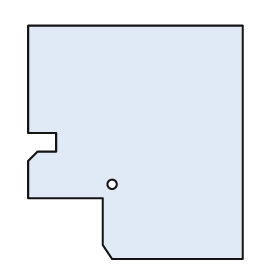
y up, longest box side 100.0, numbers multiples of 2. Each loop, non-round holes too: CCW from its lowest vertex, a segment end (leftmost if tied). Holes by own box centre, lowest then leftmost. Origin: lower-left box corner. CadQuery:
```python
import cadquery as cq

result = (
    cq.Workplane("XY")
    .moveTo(36.0, 0.0)
    .lineTo(92.0, 0.0)
    .lineTo(92.0, 100.0)
    .lineTo(0.0, 100.0)
    .lineTo(0.0, 54.0)
    .lineTo(12.0, 54.0)
    .lineTo(12.0, 46.0)
    .lineTo(4.0, 46.0)
    .lineTo(0.0, 42.0)
    .lineTo(0.0, 26.0)
    .lineTo(32.0, 26.0)
    .lineTo(32.0, 6.0)
    .close()
    .moveTo(36.0, 32.0)
    .circle(2.0)
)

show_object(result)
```